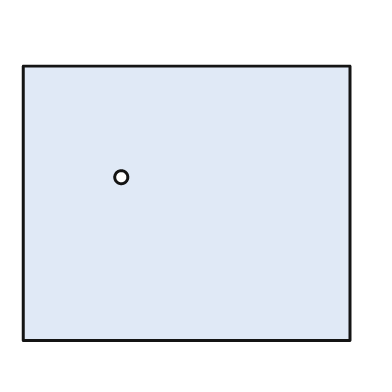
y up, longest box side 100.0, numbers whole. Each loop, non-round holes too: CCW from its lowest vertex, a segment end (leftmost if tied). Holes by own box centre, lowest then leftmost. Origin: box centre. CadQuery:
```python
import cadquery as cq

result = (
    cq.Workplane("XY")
    .moveTo(-50.0, -42.0)
    .lineTo(50.0, -42.0)
    .lineTo(50.0, 42.0)
    .lineTo(-50.0, 42.0)
    .close()
    .moveTo(-20.0, 8.0)
    .circle(2.0)
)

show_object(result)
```